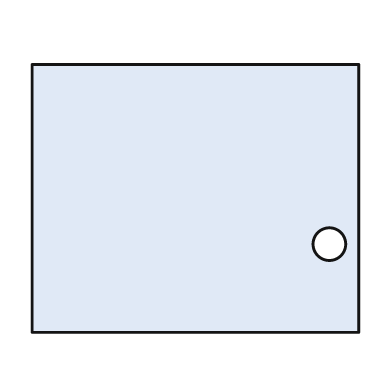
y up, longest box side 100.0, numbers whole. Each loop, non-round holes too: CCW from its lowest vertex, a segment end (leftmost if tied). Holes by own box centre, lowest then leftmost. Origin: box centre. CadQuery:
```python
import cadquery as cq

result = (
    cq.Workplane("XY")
    .moveTo(-50.0, -41.0)
    .lineTo(50.0, -41.0)
    .lineTo(50.0, 41.0)
    .lineTo(-50.0, 41.0)
    .close()
    .moveTo(41.0, -14.0)
    .circle(5.0)
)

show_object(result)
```